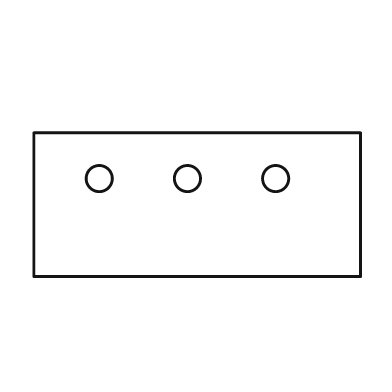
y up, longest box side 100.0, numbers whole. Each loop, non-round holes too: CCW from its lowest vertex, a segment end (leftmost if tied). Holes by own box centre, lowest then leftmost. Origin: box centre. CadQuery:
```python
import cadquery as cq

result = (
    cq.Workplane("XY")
    .moveTo(-50.0, -22.0)
    .lineTo(50.0, -22.0)
    .lineTo(50.0, 22.0)
    .lineTo(-50.0, 22.0)
    .close()
    .moveTo(-30.0, 8.0)
    .circle(4.0)
    .moveTo(-3.0, 8.0)
    .circle(4.0)
    .moveTo(24.0, 8.0)
    .circle(4.0)
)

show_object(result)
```